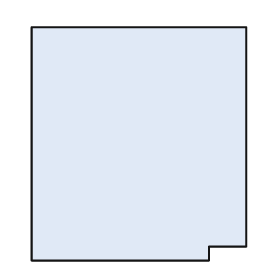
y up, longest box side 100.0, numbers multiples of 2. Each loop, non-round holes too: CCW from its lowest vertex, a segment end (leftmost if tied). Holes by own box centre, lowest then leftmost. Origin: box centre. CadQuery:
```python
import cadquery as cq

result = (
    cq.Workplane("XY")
    .moveTo(-46.0, -50.0)
    .lineTo(30.0, -50.0)
    .lineTo(30.0, -44.0)
    .lineTo(46.0, -44.0)
    .lineTo(46.0, 50.0)
    .lineTo(-46.0, 50.0)
    .close()
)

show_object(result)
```